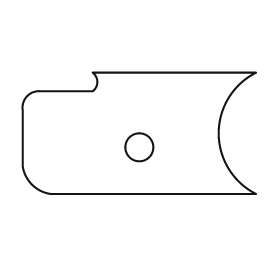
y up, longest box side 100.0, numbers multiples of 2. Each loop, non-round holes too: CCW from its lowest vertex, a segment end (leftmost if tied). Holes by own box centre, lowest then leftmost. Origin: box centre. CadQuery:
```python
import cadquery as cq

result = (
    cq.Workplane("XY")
    .moveTo(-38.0, -26.0)
    .lineTo(50.0, -26.0)
    .threePointArc((34.0, 0.0), (50.0, 26.0))
    .lineTo(-20.0, 26.0)
    .threePointArc((-18.0, 22.0), (-20.0, 18.0))
    .lineTo(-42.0, 18.0)
    .threePointArc((-48.0, 16.0), (-50.0, 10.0))
    .lineTo(-50.0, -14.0)
    .threePointArc((-46.0, -22.0), (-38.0, -26.0))
    .close()
    .moveTo(0.0, -6.0)
    .circle(6.0)
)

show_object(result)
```